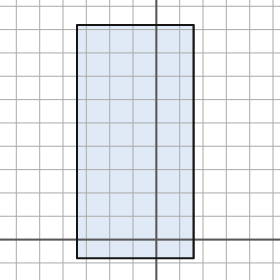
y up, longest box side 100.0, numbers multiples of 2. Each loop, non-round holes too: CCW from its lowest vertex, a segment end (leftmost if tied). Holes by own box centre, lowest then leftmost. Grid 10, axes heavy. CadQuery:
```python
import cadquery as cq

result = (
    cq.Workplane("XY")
    .moveTo(-34.0, -8.0)
    .lineTo(16.0, -8.0)
    .lineTo(16.0, 92.0)
    .lineTo(-34.0, 92.0)
    .close()
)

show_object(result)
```